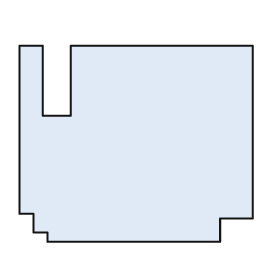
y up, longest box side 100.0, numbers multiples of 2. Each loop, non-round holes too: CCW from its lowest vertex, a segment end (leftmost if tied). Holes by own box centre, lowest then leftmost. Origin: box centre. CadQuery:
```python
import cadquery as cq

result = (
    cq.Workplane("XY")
    .moveTo(-38.0, -42.0)
    .lineTo(36.0, -42.0)
    .lineTo(36.0, -32.0)
    .lineTo(50.0, -32.0)
    .lineTo(50.0, 42.0)
    .lineTo(-28.0, 42.0)
    .lineTo(-28.0, 12.0)
    .lineTo(-40.0, 12.0)
    .lineTo(-40.0, 42.0)
    .lineTo(-50.0, 42.0)
    .lineTo(-50.0, -30.0)
    .lineTo(-44.0, -30.0)
    .lineTo(-44.0, -38.0)
    .lineTo(-38.0, -38.0)
    .close()
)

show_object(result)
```